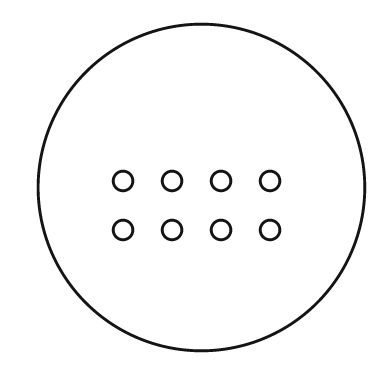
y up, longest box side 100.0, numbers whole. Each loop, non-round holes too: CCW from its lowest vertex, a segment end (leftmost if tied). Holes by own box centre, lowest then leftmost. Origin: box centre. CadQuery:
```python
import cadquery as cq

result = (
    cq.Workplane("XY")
    .moveTo(0.0, 0.0)
    .circle(50.0)
    .moveTo(-24.0, -13.0)
    .circle(3.0)
    .moveTo(-9.0, -13.0)
    .circle(3.0)
    .moveTo(6.0, -13.0)
    .circle(3.0)
    .moveTo(21.0, -13.0)
    .circle(3.0)
    .moveTo(-24.0, 2.0)
    .circle(3.0)
    .moveTo(-9.0, 2.0)
    .circle(3.0)
    .moveTo(6.0, 2.0)
    .circle(3.0)
    .moveTo(21.0, 2.0)
    .circle(3.0)
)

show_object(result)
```